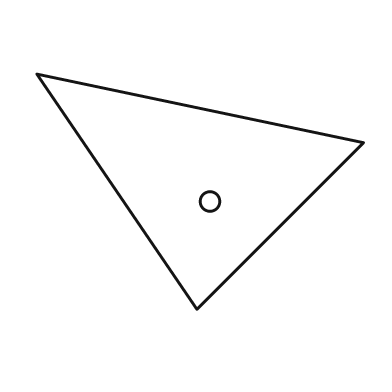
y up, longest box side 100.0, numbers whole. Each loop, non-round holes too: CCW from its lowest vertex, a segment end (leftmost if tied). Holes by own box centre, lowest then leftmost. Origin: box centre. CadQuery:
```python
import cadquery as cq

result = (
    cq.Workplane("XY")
    .moveTo(-1.0, -36.0)
    .lineTo(50.0, 15.0)
    .lineTo(-50.0, 36.0)
    .close()
    .moveTo(3.0, -3.0)
    .circle(3.0)
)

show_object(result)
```